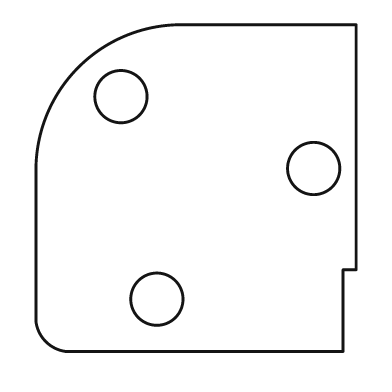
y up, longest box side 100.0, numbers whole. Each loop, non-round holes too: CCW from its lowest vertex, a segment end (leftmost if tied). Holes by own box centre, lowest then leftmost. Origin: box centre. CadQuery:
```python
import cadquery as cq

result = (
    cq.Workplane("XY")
    .moveTo(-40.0, -50.0)
    .lineTo(45.0, -50.0)
    .lineTo(45.0, -25.0)
    .lineTo(49.0, -25.0)
    .lineTo(49.0, 50.0)
    .lineTo(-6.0, 50.0)
    .threePointArc((-36.0, 37.0), (-49.0, 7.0))
    .lineTo(-49.0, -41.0)
    .threePointArc((-46.0, -47.0), (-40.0, -50.0))
    .close()
    .moveTo(-12.0, -34.0)
    .circle(8.0)
    .moveTo(36.0, 6.0)
    .circle(8.0)
    .moveTo(-23.0, 28.0)
    .circle(8.0)
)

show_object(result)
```